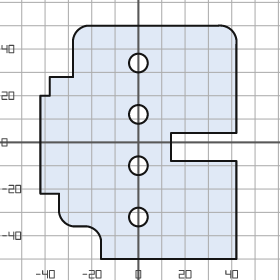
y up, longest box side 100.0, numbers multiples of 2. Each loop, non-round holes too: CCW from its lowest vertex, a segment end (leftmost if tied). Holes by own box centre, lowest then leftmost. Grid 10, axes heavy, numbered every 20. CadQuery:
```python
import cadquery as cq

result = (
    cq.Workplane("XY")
    .moveTo(-16.0, -50.0)
    .lineTo(42.0, -50.0)
    .lineTo(42.0, -8.0)
    .lineTo(14.0, -8.0)
    .lineTo(14.0, 4.0)
    .lineTo(42.0, 4.0)
    .lineTo(42.0, 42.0)
    .threePointArc((40.0, 48.0), (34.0, 50.0))
    .lineTo(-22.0, 50.0)
    .threePointArc((-26.0, 48.0), (-28.0, 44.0))
    .lineTo(-28.0, 28.0)
    .lineTo(-38.0, 28.0)
    .lineTo(-38.0, 20.0)
    .lineTo(-42.0, 20.0)
    .lineTo(-42.0, -22.0)
    .lineTo(-34.0, -22.0)
    .lineTo(-34.0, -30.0)
    .threePointArc((-32.0, -34.0), (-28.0, -36.0))
    .lineTo(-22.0, -36.0)
    .threePointArc((-18.0, -38.0), (-16.0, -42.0))
    .close()
    .moveTo(0.0, -32.0)
    .circle(4.0)
    .moveTo(0.0, -10.0)
    .circle(4.0)
    .moveTo(0.0, 12.0)
    .circle(4.0)
    .moveTo(0.0, 34.0)
    .circle(4.0)
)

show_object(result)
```